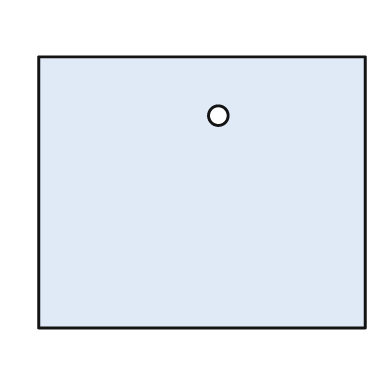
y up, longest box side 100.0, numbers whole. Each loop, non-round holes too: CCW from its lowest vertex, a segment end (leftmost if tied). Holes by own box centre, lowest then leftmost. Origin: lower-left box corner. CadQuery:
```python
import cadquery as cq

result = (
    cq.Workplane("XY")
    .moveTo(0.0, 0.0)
    .lineTo(100.0, 0.0)
    .lineTo(100.0, 83.0)
    .lineTo(0.0, 83.0)
    .close()
    .moveTo(55.0, 65.0)
    .circle(3.0)
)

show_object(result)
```